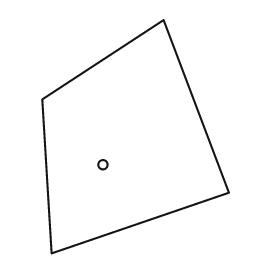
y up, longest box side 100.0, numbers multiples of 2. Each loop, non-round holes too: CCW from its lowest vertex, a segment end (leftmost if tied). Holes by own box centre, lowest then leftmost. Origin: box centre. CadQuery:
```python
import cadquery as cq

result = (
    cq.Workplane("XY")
    .moveTo(-36.0, -50.0)
    .lineTo(40.0, -24.0)
    .lineTo(12.0, 50.0)
    .lineTo(-40.0, 16.0)
    .close()
    .moveTo(-14.0, -12.0)
    .circle(2.0)
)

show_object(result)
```